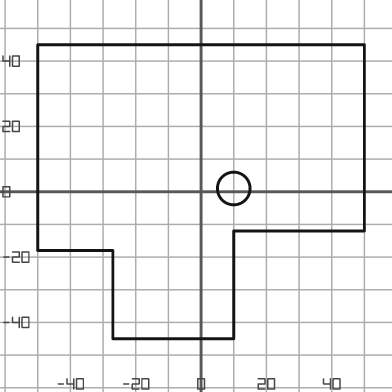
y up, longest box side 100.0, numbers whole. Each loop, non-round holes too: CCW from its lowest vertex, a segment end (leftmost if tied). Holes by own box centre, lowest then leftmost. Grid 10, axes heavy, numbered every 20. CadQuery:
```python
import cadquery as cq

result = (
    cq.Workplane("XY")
    .moveTo(-27.0, -45.0)
    .lineTo(10.0, -45.0)
    .lineTo(10.0, -12.0)
    .lineTo(50.0, -12.0)
    .lineTo(50.0, 45.0)
    .lineTo(-50.0, 45.0)
    .lineTo(-50.0, -18.0)
    .lineTo(-27.0, -18.0)
    .close()
    .moveTo(10.0, 1.0)
    .circle(5.0)
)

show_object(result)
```